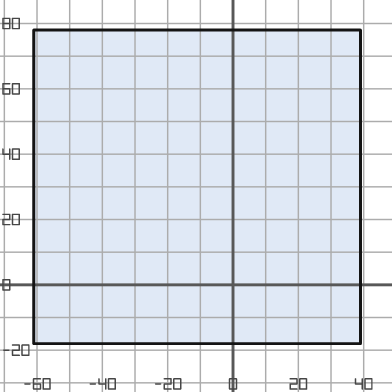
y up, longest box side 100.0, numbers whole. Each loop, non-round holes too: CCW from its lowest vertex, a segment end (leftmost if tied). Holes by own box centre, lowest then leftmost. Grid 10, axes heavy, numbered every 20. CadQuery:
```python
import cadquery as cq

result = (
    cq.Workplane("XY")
    .moveTo(-61.0, -18.0)
    .lineTo(39.0, -18.0)
    .lineTo(39.0, 78.0)
    .lineTo(-61.0, 78.0)
    .close()
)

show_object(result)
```